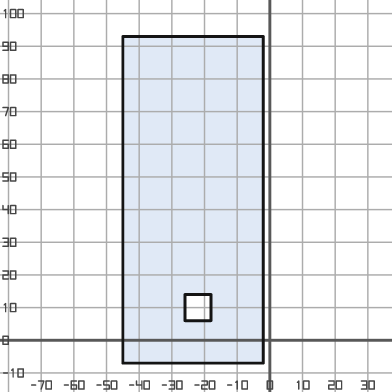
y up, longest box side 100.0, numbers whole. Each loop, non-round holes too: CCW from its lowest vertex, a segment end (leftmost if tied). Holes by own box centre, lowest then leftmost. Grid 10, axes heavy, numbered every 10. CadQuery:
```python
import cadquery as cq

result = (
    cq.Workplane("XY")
    .moveTo(-45.0, -7.0)
    .lineTo(-2.0, -7.0)
    .lineTo(-2.0, 93.0)
    .lineTo(-45.0, 93.0)
    .close()
    .moveTo(-26.0, 6.0)
    .lineTo(-18.0, 6.0)
    .lineTo(-18.0, 14.0)
    .lineTo(-26.0, 14.0)
    .close()
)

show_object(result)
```